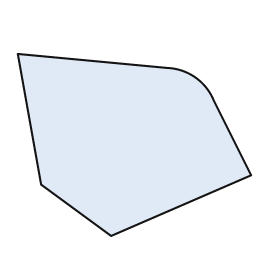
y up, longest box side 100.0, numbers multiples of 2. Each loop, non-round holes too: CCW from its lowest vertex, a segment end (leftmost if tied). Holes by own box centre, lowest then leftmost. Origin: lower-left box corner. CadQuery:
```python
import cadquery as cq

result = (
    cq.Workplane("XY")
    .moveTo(40.0, 0.0)
    .lineTo(100.0, 26.0)
    .lineTo(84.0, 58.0)
    .threePointArc((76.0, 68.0), (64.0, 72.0))
    .lineTo(0.0, 78.0)
    .lineTo(10.0, 22.0)
    .close()
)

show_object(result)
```